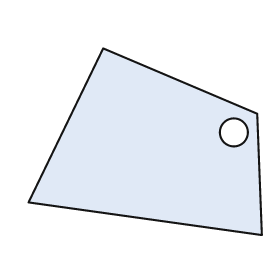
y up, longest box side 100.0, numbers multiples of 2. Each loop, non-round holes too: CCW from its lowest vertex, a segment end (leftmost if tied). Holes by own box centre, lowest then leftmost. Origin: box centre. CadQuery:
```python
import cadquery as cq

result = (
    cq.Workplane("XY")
    .moveTo(50.0, -40.0)
    .lineTo(48.0, 12.0)
    .lineTo(-18.0, 40.0)
    .lineTo(-50.0, -26.0)
    .close()
    .moveTo(38.0, 4.0)
    .circle(6.0)
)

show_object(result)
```